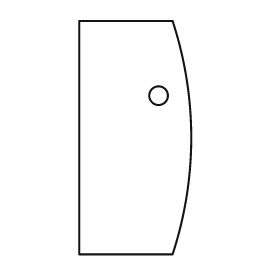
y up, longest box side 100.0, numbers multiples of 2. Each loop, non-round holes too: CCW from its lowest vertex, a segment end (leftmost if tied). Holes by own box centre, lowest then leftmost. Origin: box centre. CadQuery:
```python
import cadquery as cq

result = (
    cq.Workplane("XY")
    .moveTo(-24.0, -50.0)
    .lineTo(16.0, -50.0)
    .threePointArc((24.0, 0.0), (16.0, 50.0))
    .lineTo(-24.0, 50.0)
    .close()
    .moveTo(10.0, 18.0)
    .circle(4.0)
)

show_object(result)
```